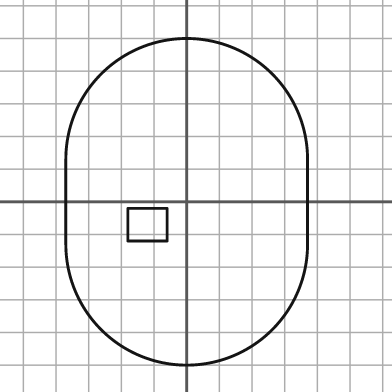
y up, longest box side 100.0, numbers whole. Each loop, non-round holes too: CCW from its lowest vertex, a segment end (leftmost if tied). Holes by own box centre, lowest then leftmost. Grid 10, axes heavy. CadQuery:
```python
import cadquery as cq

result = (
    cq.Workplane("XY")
    .moveTo(-37.0, -13.0)
    .threePointArc((0.0, -50.0), (37.0, -13.0))
    .lineTo(37.0, 13.0)
    .threePointArc((0.0, 50.0), (-37.0, 13.0))
    .close()
    .moveTo(-18.0, -12.0)
    .lineTo(-6.0, -12.0)
    .lineTo(-6.0, -2.0)
    .lineTo(-18.0, -2.0)
    .close()
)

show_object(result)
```